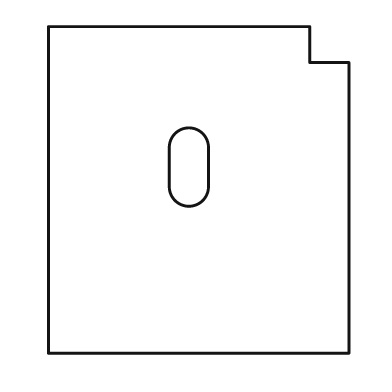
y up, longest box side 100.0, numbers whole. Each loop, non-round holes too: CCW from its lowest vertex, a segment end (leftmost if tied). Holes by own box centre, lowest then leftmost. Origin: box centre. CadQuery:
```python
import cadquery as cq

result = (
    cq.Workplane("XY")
    .moveTo(-46.0, -50.0)
    .lineTo(46.0, -50.0)
    .lineTo(46.0, 39.0)
    .lineTo(34.0, 39.0)
    .lineTo(34.0, 50.0)
    .lineTo(-46.0, 50.0)
    .close()
    .moveTo(-9.0, 1.0)
    .threePointArc((-3.0, -5.0), (3.0, 1.0))
    .lineTo(3.0, 13.0)
    .threePointArc((-3.0, 19.0), (-9.0, 13.0))
    .close()
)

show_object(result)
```